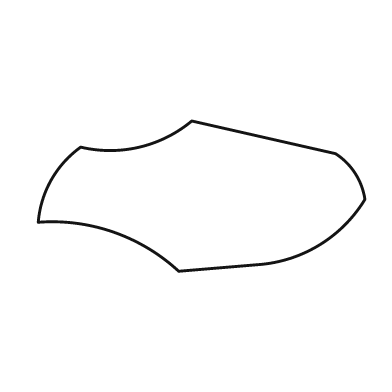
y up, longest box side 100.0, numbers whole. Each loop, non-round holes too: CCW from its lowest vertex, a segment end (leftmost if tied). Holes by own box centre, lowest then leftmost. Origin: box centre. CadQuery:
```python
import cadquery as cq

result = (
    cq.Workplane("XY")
    .moveTo(-7.0, -23.0)
    .lineTo(17.0, -21.0)
    .threePointArc((36.0, -15.0), (50.0, -1.0))
    .threePointArc((47.0, 7.0), (41.0, 13.0))
    .lineTo(-3.0, 23.0)
    .threePointArc((-19.0, 15.0), (-37.0, 15.0))
    .threePointArc((-46.0, 5.0), (-50.0, -8.0))
    .threePointArc((-27.0, -11.0), (-7.0, -23.0))
    .close()
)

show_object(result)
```